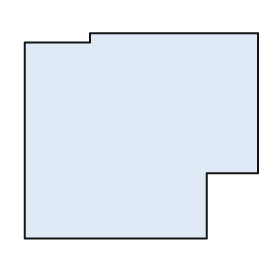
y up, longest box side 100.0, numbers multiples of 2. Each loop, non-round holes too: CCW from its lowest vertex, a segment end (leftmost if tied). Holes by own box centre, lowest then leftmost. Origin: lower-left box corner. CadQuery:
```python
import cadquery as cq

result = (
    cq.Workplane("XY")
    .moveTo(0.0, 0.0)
    .lineTo(78.0, 0.0)
    .lineTo(78.0, 28.0)
    .lineTo(100.0, 28.0)
    .lineTo(100.0, 88.0)
    .lineTo(28.0, 88.0)
    .lineTo(28.0, 84.0)
    .lineTo(0.0, 84.0)
    .close()
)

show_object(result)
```